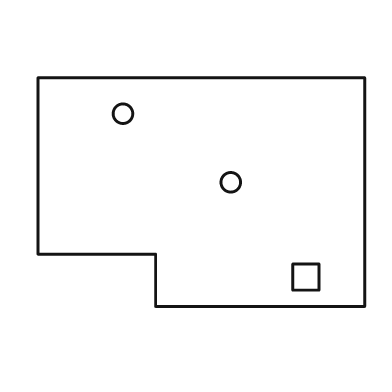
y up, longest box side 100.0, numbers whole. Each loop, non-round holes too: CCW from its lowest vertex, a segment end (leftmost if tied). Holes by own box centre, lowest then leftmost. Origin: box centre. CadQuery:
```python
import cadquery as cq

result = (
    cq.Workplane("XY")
    .moveTo(-14.0, -35.0)
    .lineTo(50.0, -35.0)
    .lineTo(50.0, 35.0)
    .lineTo(-50.0, 35.0)
    .lineTo(-50.0, -19.0)
    .lineTo(-14.0, -19.0)
    .close()
    .moveTo(28.0, -30.0)
    .lineTo(36.0, -30.0)
    .lineTo(36.0, -22.0)
    .lineTo(28.0, -22.0)
    .close()
    .moveTo(9.0, 3.0)
    .circle(3.0)
    .moveTo(-24.0, 24.0)
    .circle(3.0)
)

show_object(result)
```